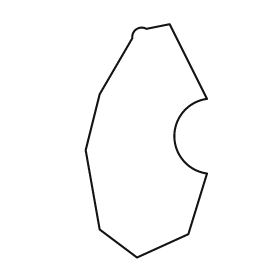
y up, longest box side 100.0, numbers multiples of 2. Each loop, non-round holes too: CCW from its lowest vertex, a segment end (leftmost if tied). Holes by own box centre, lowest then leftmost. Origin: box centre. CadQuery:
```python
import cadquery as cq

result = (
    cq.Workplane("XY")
    .moveTo(-4.0, -50.0)
    .lineTo(18.0, -40.0)
    .lineTo(26.0, -14.0)
    .threePointArc((12.0, 2.0), (26.0, 18.0))
    .lineTo(10.0, 50.0)
    .lineTo(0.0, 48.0)
    .threePointArc((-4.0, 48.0), (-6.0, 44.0))
    .lineTo(-20.0, 20.0)
    .lineTo(-26.0, -4.0)
    .lineTo(-20.0, -38.0)
    .close()
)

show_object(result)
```